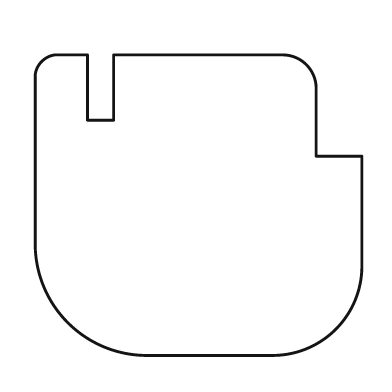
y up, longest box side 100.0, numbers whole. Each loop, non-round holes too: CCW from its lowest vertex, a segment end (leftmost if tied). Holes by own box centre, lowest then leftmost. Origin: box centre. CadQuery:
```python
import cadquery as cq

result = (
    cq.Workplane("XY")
    .moveTo(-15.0, -46.0)
    .lineTo(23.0, -46.0)
    .threePointArc((42.0, -38.0), (50.0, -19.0))
    .lineTo(50.0, 15.0)
    .lineTo(36.0, 15.0)
    .lineTo(36.0, 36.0)
    .threePointArc((33.0, 43.0), (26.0, 46.0))
    .lineTo(-26.0, 46.0)
    .lineTo(-26.0, 26.0)
    .lineTo(-34.0, 26.0)
    .lineTo(-34.0, 46.0)
    .lineTo(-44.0, 46.0)
    .threePointArc((-48.0, 44.0), (-50.0, 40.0))
    .lineTo(-50.0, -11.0)
    .threePointArc((-40.0, -36.0), (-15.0, -46.0))
    .close()
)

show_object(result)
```